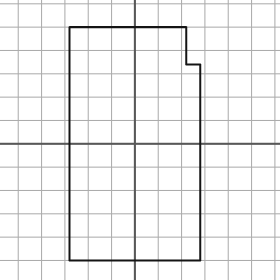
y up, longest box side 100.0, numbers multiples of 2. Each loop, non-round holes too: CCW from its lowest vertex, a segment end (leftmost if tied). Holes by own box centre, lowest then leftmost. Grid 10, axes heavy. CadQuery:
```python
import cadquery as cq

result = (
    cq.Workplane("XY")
    .moveTo(-28.0, -50.0)
    .lineTo(28.0, -50.0)
    .lineTo(28.0, 34.0)
    .lineTo(22.0, 34.0)
    .lineTo(22.0, 50.0)
    .lineTo(-28.0, 50.0)
    .close()
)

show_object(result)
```